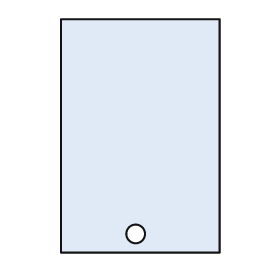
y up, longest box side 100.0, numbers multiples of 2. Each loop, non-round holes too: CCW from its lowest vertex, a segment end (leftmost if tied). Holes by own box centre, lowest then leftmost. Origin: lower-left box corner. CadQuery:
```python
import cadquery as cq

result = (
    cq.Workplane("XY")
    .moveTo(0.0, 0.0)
    .lineTo(68.0, 0.0)
    .lineTo(68.0, 100.0)
    .lineTo(0.0, 100.0)
    .close()
    .moveTo(32.0, 8.0)
    .circle(4.0)
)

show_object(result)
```